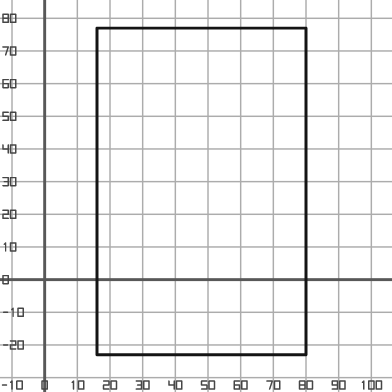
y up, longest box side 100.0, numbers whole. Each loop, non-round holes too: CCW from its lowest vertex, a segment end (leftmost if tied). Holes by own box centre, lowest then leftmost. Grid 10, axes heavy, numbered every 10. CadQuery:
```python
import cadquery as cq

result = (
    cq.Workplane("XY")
    .moveTo(16.0, -23.0)
    .lineTo(80.0, -23.0)
    .lineTo(80.0, 77.0)
    .lineTo(16.0, 77.0)
    .close()
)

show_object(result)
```